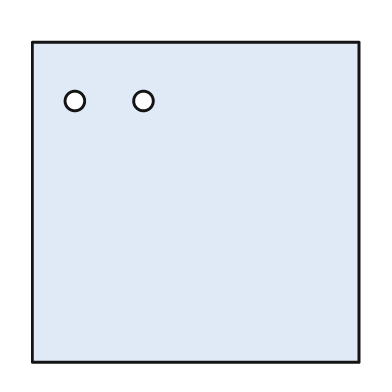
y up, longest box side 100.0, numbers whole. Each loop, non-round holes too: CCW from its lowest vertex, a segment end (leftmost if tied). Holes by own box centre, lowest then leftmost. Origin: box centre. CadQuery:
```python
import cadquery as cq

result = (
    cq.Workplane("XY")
    .moveTo(-50.0, -49.0)
    .lineTo(50.0, -49.0)
    .lineTo(50.0, 49.0)
    .lineTo(-50.0, 49.0)
    .close()
    .moveTo(-37.0, 31.0)
    .circle(3.0)
    .moveTo(-16.0, 31.0)
    .circle(3.0)
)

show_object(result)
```